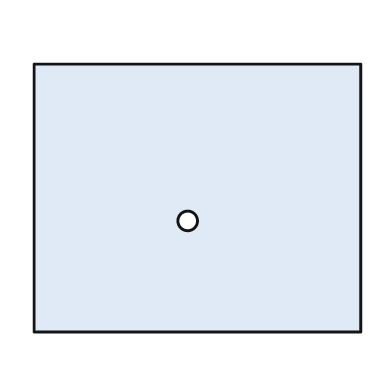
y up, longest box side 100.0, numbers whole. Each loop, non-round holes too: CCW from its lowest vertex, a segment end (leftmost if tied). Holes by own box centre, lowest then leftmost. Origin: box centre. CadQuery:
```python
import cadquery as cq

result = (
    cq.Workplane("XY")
    .moveTo(-50.0, -41.0)
    .lineTo(50.0, -41.0)
    .lineTo(50.0, 41.0)
    .lineTo(-50.0, 41.0)
    .close()
    .moveTo(-3.0, -7.0)
    .circle(3.0)
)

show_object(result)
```